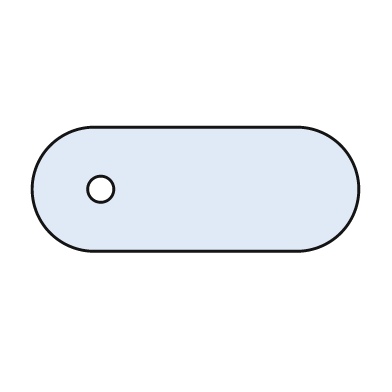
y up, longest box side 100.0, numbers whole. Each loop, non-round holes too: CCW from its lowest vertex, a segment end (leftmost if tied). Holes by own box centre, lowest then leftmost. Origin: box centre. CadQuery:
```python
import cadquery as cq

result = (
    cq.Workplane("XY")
    .moveTo(-31.0, -19.0)
    .lineTo(31.0, -19.0)
    .threePointArc((50.0, 0.0), (31.0, 19.0))
    .lineTo(-31.0, 19.0)
    .threePointArc((-50.0, 0.0), (-31.0, -19.0))
    .close()
    .moveTo(-29.0, 0.0)
    .circle(4.0)
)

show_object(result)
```